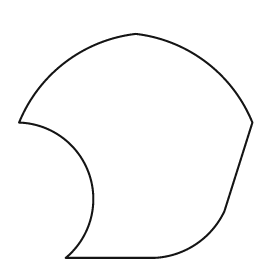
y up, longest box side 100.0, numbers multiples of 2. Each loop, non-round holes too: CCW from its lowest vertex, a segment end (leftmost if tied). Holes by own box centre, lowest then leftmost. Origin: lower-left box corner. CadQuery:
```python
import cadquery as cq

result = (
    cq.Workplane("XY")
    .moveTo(20.0, 0.0)
    .lineTo(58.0, 0.0)
    .threePointArc((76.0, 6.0), (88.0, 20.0))
    .lineTo(100.0, 58.0)
    .threePointArc((80.0, 84.0), (50.0, 96.0))
    .threePointArc((20.0, 84.0), (0.0, 58.0))
    .threePointArc((30.0, 36.0), (20.0, 0.0))
    .close()
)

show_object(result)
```